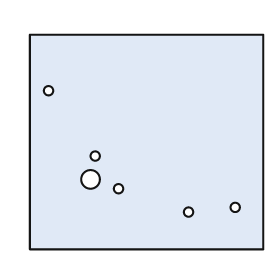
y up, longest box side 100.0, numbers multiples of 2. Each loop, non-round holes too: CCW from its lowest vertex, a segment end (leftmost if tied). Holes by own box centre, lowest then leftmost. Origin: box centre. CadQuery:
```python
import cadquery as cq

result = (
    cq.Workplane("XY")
    .moveTo(-50.0, -46.0)
    .lineTo(50.0, -46.0)
    .lineTo(50.0, 46.0)
    .lineTo(-50.0, 46.0)
    .close()
    .moveTo(18.0, -30.0)
    .circle(2.0)
    .moveTo(38.0, -28.0)
    .circle(2.0)
    .moveTo(-12.0, -20.0)
    .circle(2.0)
    .moveTo(-24.0, -16.0)
    .circle(4.0)
    .moveTo(-22.0, -6.0)
    .circle(2.0)
    .moveTo(-42.0, 22.0)
    .circle(2.0)
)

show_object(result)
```